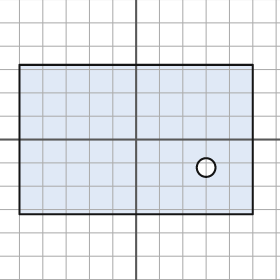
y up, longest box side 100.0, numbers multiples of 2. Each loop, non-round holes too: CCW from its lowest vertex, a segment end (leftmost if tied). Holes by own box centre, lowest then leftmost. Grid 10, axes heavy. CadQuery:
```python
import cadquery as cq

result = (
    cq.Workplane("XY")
    .moveTo(-50.0, -32.0)
    .lineTo(50.0, -32.0)
    .lineTo(50.0, 32.0)
    .lineTo(-50.0, 32.0)
    .close()
    .moveTo(30.0, -12.0)
    .circle(4.0)
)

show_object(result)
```